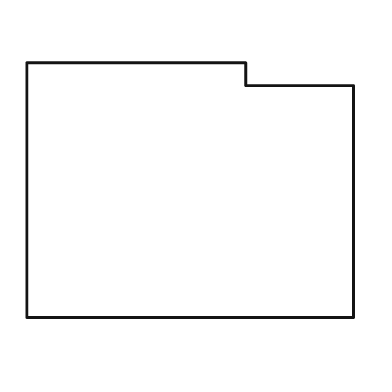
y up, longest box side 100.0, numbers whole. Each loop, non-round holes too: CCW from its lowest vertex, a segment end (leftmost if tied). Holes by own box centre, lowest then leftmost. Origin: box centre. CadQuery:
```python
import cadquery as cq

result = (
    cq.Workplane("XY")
    .moveTo(-50.0, -39.0)
    .lineTo(50.0, -39.0)
    .lineTo(50.0, 32.0)
    .lineTo(17.0, 32.0)
    .lineTo(17.0, 39.0)
    .lineTo(-50.0, 39.0)
    .close()
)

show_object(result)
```